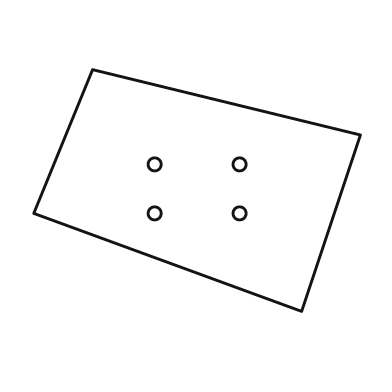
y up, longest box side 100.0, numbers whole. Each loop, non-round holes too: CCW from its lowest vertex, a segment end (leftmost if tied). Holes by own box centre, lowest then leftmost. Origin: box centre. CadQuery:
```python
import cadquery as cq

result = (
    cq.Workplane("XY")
    .moveTo(32.0, -37.0)
    .lineTo(50.0, 17.0)
    .lineTo(-32.0, 37.0)
    .lineTo(-50.0, -7.0)
    .close()
    .moveTo(-13.0, -7.0)
    .circle(2.0)
    .moveTo(13.0, -7.0)
    .circle(2.0)
    .moveTo(-13.0, 8.0)
    .circle(2.0)
    .moveTo(13.0, 8.0)
    .circle(2.0)
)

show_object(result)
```